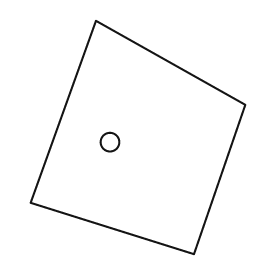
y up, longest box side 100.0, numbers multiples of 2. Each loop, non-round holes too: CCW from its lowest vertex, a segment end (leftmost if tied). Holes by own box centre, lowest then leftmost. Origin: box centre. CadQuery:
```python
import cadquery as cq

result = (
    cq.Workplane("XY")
    .moveTo(24.0, -50.0)
    .lineTo(46.0, 14.0)
    .lineTo(-18.0, 50.0)
    .lineTo(-46.0, -28.0)
    .close()
    .moveTo(-12.0, -2.0)
    .circle(4.0)
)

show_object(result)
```